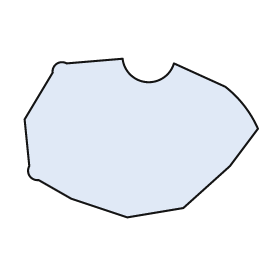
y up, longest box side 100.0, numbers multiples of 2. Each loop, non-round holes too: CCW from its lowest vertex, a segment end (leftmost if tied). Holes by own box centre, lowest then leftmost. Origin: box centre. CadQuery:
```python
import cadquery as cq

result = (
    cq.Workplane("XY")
    .moveTo(-6.0, -34.0)
    .lineTo(18.0, -30.0)
    .lineTo(38.0, -12.0)
    .lineTo(50.0, 4.0)
    .threePointArc((44.0, 14.0), (36.0, 22.0))
    .lineTo(14.0, 32.0)
    .threePointArc((2.0, 24.0), (-8.0, 34.0))
    .lineTo(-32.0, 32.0)
    .threePointArc((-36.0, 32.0), (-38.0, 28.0))
    .lineTo(-50.0, 8.0)
    .lineTo(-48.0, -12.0)
    .threePointArc((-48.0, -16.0), (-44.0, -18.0))
    .lineTo(-30.0, -26.0)
    .close()
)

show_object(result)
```